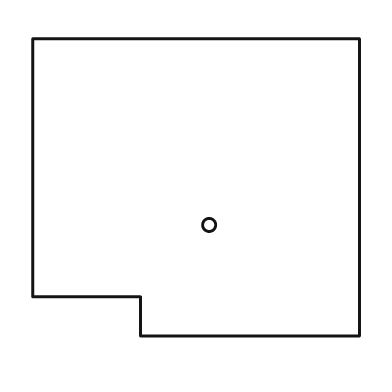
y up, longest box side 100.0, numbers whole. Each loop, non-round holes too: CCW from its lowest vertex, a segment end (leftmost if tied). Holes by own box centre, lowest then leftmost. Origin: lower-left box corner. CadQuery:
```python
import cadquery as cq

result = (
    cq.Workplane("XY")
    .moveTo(33.0, 0.0)
    .lineTo(100.0, 0.0)
    .lineTo(100.0, 91.0)
    .lineTo(0.0, 91.0)
    .lineTo(0.0, 12.0)
    .lineTo(33.0, 12.0)
    .close()
    .moveTo(54.0, 34.0)
    .circle(2.0)
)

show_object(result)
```